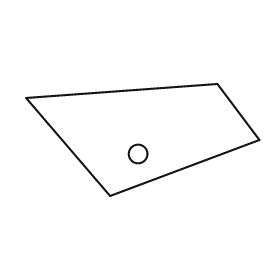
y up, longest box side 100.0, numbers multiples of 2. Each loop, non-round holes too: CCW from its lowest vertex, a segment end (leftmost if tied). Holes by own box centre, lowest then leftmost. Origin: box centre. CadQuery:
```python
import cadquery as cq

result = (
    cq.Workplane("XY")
    .moveTo(-14.0, -24.0)
    .lineTo(50.0, 0.0)
    .lineTo(32.0, 24.0)
    .lineTo(-50.0, 18.0)
    .close()
    .moveTo(-2.0, -6.0)
    .circle(4.0)
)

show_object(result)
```